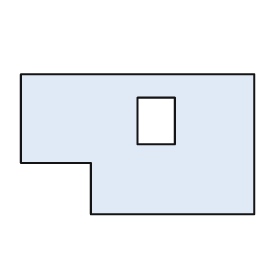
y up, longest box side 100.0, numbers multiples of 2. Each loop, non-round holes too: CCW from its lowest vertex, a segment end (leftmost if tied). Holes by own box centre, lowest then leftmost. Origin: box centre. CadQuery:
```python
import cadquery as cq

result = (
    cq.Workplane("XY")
    .moveTo(-20.0, -30.0)
    .lineTo(50.0, -30.0)
    .lineTo(50.0, 30.0)
    .lineTo(-50.0, 30.0)
    .lineTo(-50.0, -8.0)
    .lineTo(-20.0, -8.0)
    .close()
    .moveTo(0.0, 0.0)
    .lineTo(16.0, 0.0)
    .lineTo(16.0, 20.0)
    .lineTo(0.0, 20.0)
    .close()
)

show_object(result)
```